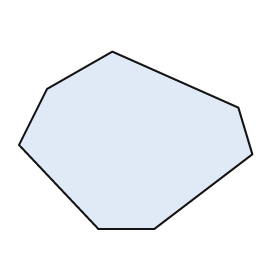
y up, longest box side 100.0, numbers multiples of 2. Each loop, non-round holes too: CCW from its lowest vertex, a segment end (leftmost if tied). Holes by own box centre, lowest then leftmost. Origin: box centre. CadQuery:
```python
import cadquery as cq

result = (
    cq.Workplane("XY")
    .moveTo(-16.0, -38.0)
    .lineTo(8.0, -38.0)
    .lineTo(50.0, -6.0)
    .lineTo(44.0, 14.0)
    .lineTo(-10.0, 38.0)
    .lineTo(-38.0, 22.0)
    .lineTo(-50.0, -2.0)
    .close()
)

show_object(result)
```